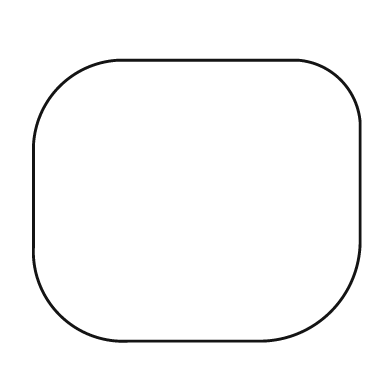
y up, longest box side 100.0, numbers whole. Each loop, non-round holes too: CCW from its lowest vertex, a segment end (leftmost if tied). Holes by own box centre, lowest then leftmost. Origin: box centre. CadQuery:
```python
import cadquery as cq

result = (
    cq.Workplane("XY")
    .moveTo(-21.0, -43.0)
    .lineTo(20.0, -43.0)
    .threePointArc((41.0, -34.0), (50.0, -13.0))
    .lineTo(50.0, 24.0)
    .threePointArc((44.0, 37.0), (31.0, 43.0))
    .lineTo(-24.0, 43.0)
    .threePointArc((-42.0, 35.0), (-50.0, 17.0))
    .lineTo(-50.0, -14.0)
    .threePointArc((-42.0, -35.0), (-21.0, -43.0))
    .close()
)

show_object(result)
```